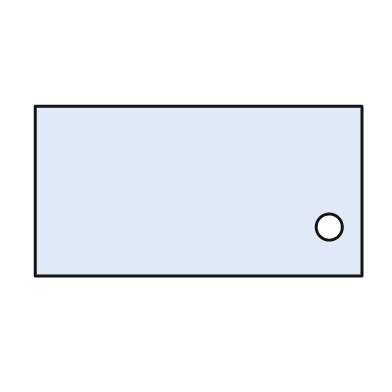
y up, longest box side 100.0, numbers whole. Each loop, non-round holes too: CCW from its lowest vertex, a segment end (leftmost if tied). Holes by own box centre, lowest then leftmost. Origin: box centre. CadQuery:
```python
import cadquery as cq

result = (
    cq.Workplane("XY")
    .moveTo(-50.0, -26.0)
    .lineTo(50.0, -26.0)
    .lineTo(50.0, 26.0)
    .lineTo(-50.0, 26.0)
    .close()
    .moveTo(40.0, -11.0)
    .circle(4.0)
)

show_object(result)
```